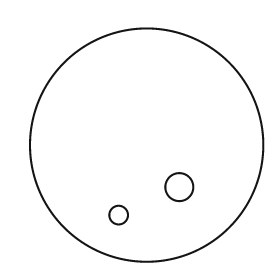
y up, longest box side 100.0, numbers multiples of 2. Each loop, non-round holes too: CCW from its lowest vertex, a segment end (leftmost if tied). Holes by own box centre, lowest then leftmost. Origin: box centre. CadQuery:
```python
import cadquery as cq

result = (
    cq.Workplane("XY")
    .moveTo(0.0, 0.0)
    .circle(50.0)
    .moveTo(-12.0, -30.0)
    .circle(4.0)
    .moveTo(14.0, -18.0)
    .circle(6.0)
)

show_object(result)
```